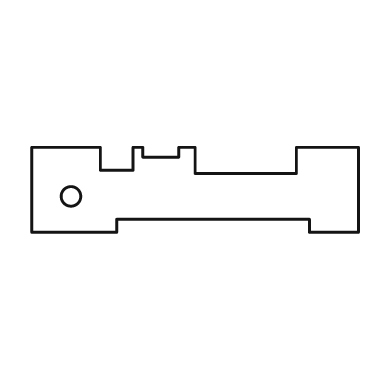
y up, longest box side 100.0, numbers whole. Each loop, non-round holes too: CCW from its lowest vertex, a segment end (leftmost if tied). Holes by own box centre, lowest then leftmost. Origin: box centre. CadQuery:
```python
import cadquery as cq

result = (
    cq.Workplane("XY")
    .moveTo(-50.0, -13.0)
    .lineTo(-24.0, -13.0)
    .lineTo(-24.0, -9.0)
    .lineTo(35.0, -9.0)
    .lineTo(35.0, -13.0)
    .lineTo(50.0, -13.0)
    .lineTo(50.0, 13.0)
    .lineTo(31.0, 13.0)
    .lineTo(31.0, 5.0)
    .lineTo(0.0, 5.0)
    .lineTo(0.0, 13.0)
    .lineTo(-5.0, 13.0)
    .lineTo(-5.0, 10.0)
    .lineTo(-16.0, 10.0)
    .lineTo(-16.0, 13.0)
    .lineTo(-19.0, 13.0)
    .lineTo(-19.0, 6.0)
    .lineTo(-29.0, 6.0)
    .lineTo(-29.0, 13.0)
    .lineTo(-50.0, 13.0)
    .close()
    .moveTo(-38.0, -2.0)
    .circle(3.0)
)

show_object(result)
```